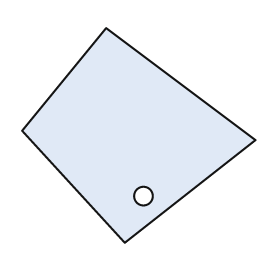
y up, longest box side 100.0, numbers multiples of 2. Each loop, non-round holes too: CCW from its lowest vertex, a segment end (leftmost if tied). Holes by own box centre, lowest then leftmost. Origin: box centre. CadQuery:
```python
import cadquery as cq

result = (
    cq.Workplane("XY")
    .moveTo(-6.0, -46.0)
    .lineTo(50.0, -2.0)
    .lineTo(-14.0, 46.0)
    .lineTo(-50.0, 2.0)
    .close()
    .moveTo(2.0, -26.0)
    .circle(4.0)
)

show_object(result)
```